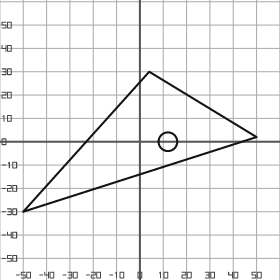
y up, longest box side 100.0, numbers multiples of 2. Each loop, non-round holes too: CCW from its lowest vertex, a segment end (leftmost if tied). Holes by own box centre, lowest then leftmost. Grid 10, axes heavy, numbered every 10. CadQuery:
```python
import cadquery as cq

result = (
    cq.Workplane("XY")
    .moveTo(-50.0, -30.0)
    .lineTo(50.0, 2.0)
    .lineTo(4.0, 30.0)
    .close()
    .moveTo(12.0, 0.0)
    .circle(4.0)
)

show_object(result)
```